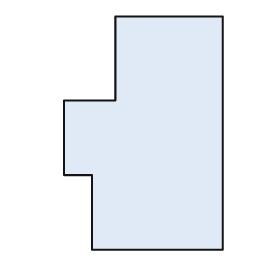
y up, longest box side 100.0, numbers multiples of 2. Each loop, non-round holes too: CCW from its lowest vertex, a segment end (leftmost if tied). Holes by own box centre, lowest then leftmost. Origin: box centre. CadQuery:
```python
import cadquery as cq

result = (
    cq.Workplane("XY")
    .moveTo(-22.0, -50.0)
    .lineTo(34.0, -50.0)
    .lineTo(34.0, 50.0)
    .lineTo(-12.0, 50.0)
    .lineTo(-12.0, 14.0)
    .lineTo(-34.0, 14.0)
    .lineTo(-34.0, -18.0)
    .lineTo(-22.0, -18.0)
    .close()
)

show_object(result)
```